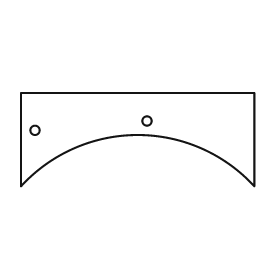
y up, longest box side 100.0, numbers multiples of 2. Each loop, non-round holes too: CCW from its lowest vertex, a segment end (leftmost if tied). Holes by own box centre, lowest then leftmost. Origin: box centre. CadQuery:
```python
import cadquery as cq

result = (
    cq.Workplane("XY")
    .moveTo(-50.0, -20.0)
    .threePointArc((0.0, 2.0), (50.0, -20.0))
    .lineTo(50.0, 20.0)
    .lineTo(-50.0, 20.0)
    .close()
    .moveTo(-44.0, 4.0)
    .circle(2.0)
    .moveTo(4.0, 8.0)
    .circle(2.0)
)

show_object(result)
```